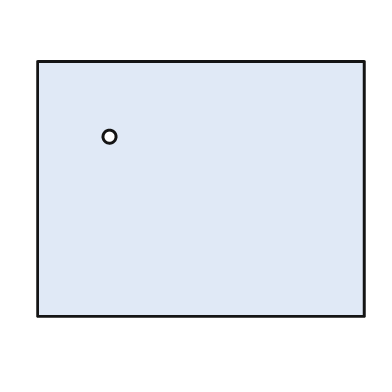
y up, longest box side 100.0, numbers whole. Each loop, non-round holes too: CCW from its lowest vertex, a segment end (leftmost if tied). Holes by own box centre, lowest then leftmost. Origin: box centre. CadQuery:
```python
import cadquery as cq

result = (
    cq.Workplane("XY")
    .moveTo(-50.0, -39.0)
    .lineTo(50.0, -39.0)
    .lineTo(50.0, 39.0)
    .lineTo(-50.0, 39.0)
    .close()
    .moveTo(-28.0, 16.0)
    .circle(2.0)
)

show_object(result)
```